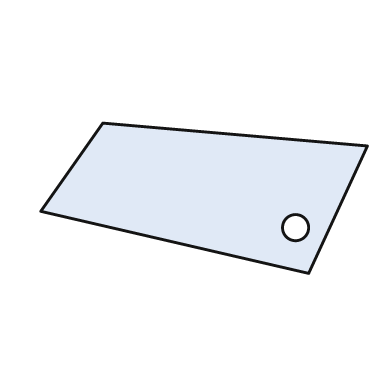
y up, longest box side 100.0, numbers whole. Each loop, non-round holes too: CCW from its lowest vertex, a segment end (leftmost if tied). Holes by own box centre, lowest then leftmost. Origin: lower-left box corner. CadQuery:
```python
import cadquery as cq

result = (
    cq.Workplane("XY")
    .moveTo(82.0, 0.0)
    .lineTo(100.0, 39.0)
    .lineTo(19.0, 46.0)
    .lineTo(0.0, 19.0)
    .close()
    .moveTo(78.0, 14.0)
    .circle(4.0)
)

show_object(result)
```